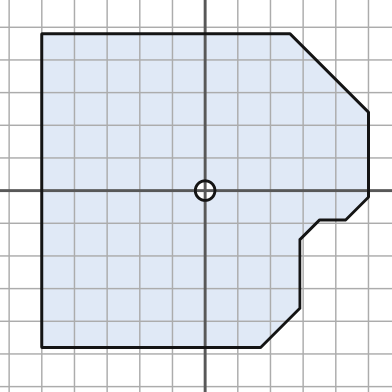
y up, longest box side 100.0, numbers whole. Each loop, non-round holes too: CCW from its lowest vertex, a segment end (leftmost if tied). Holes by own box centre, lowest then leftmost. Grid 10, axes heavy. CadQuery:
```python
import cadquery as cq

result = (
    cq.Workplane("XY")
    .moveTo(-50.0, -48.0)
    .lineTo(17.0, -48.0)
    .lineTo(29.0, -36.0)
    .lineTo(29.0, -15.0)
    .lineTo(35.0, -9.0)
    .lineTo(43.0, -9.0)
    .lineTo(50.0, -2.0)
    .lineTo(50.0, 24.0)
    .lineTo(26.0, 48.0)
    .lineTo(-50.0, 48.0)
    .close()
    .moveTo(0.0, 0.0)
    .circle(3.0)
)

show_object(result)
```